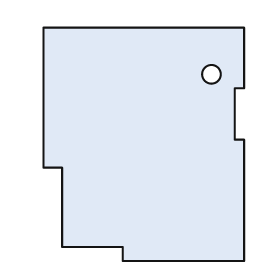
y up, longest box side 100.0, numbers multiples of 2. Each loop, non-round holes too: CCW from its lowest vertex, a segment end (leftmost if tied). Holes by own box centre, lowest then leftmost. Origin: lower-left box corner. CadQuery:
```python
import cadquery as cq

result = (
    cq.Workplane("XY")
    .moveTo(34.0, 0.0)
    .lineTo(86.0, 0.0)
    .lineTo(86.0, 52.0)
    .lineTo(82.0, 52.0)
    .lineTo(82.0, 74.0)
    .lineTo(86.0, 74.0)
    .lineTo(86.0, 100.0)
    .lineTo(0.0, 100.0)
    .lineTo(0.0, 40.0)
    .lineTo(8.0, 40.0)
    .lineTo(8.0, 6.0)
    .lineTo(34.0, 6.0)
    .close()
    .moveTo(72.0, 80.0)
    .circle(4.0)
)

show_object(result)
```